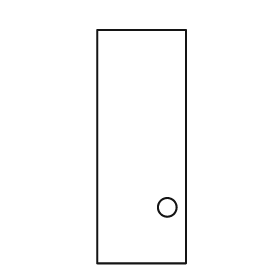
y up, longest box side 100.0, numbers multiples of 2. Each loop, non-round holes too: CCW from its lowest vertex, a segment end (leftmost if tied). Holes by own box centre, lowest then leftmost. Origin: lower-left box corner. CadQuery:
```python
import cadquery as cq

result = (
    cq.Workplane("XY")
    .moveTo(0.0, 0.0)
    .lineTo(38.0, 0.0)
    .lineTo(38.0, 100.0)
    .lineTo(0.0, 100.0)
    .close()
    .moveTo(30.0, 24.0)
    .circle(4.0)
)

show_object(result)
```